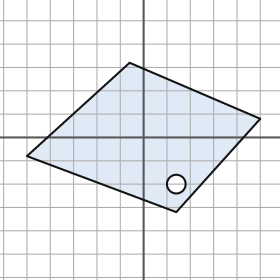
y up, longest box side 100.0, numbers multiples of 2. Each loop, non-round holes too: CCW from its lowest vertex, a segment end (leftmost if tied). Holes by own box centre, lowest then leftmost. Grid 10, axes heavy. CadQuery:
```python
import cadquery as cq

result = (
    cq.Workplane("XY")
    .moveTo(14.0, -32.0)
    .lineTo(50.0, 8.0)
    .lineTo(-6.0, 32.0)
    .lineTo(-50.0, -8.0)
    .close()
    .moveTo(14.0, -20.0)
    .circle(4.0)
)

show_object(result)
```